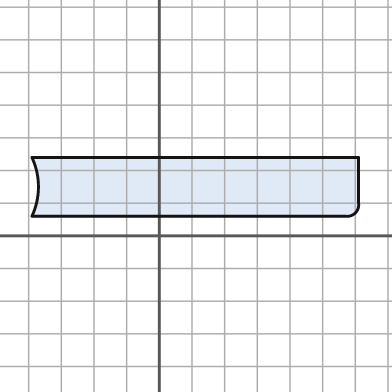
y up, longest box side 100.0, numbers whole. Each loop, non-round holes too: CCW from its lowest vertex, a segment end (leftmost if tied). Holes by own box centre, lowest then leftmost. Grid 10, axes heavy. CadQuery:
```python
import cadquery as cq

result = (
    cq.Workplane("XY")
    .moveTo(-39.0, 6.0)
    .lineTo(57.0, 6.0)
    .threePointArc((60.0, 7.0), (61.0, 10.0))
    .lineTo(61.0, 24.0)
    .lineTo(-39.0, 24.0)
    .threePointArc((-37.0, 15.0), (-39.0, 6.0))
    .close()
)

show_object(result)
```